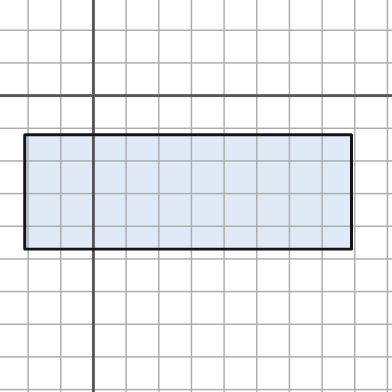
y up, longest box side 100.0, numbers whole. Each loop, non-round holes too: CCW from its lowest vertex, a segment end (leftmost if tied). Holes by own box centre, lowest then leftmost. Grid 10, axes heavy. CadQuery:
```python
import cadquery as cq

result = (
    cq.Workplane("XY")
    .moveTo(-21.0, -47.0)
    .lineTo(79.0, -47.0)
    .lineTo(79.0, -12.0)
    .lineTo(-21.0, -12.0)
    .close()
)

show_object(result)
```